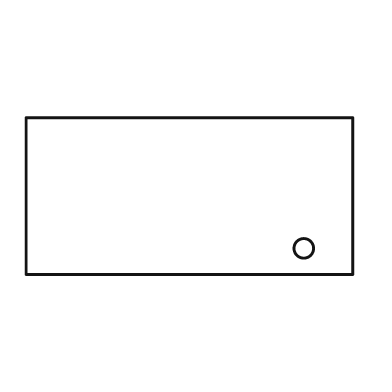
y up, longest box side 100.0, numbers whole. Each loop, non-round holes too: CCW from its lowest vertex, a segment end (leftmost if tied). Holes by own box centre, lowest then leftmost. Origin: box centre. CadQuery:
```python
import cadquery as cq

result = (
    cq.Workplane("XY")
    .moveTo(-50.0, -24.0)
    .lineTo(50.0, -24.0)
    .lineTo(50.0, 24.0)
    .lineTo(-50.0, 24.0)
    .close()
    .moveTo(35.0, -16.0)
    .circle(3.0)
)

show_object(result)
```